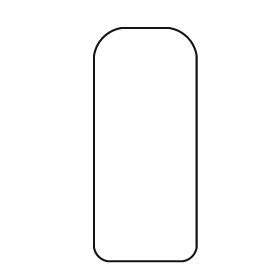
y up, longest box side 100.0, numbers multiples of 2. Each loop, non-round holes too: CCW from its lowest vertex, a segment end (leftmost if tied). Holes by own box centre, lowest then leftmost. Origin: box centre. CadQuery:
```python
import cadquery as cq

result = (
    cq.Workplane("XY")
    .moveTo(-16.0, -50.0)
    .lineTo(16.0, -50.0)
    .threePointArc((20.0, -48.0), (22.0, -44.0))
    .lineTo(22.0, 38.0)
    .threePointArc((18.0, 46.0), (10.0, 50.0))
    .lineTo(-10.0, 50.0)
    .threePointArc((-18.0, 46.0), (-22.0, 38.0))
    .lineTo(-22.0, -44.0)
    .threePointArc((-20.0, -48.0), (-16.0, -50.0))
    .close()
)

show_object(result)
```